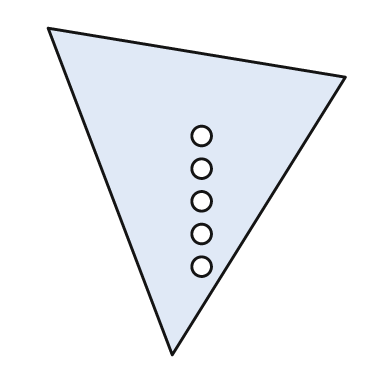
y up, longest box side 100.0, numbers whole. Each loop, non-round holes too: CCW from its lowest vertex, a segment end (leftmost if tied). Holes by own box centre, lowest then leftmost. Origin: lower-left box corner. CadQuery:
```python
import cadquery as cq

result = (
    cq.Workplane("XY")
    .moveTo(38.0, 0.0)
    .lineTo(91.0, 85.0)
    .lineTo(0.0, 100.0)
    .close()
    .moveTo(47.0, 27.0)
    .circle(3.0)
    .moveTo(47.0, 37.0)
    .circle(3.0)
    .moveTo(47.0, 47.0)
    .circle(3.0)
    .moveTo(47.0, 57.0)
    .circle(3.0)
    .moveTo(47.0, 67.0)
    .circle(3.0)
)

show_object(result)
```